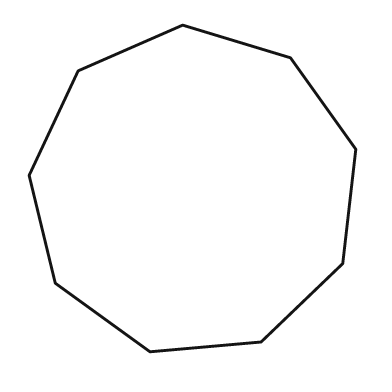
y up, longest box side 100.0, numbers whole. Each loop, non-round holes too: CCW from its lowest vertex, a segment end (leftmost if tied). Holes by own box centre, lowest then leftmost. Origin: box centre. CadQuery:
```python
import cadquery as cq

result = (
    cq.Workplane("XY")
    .moveTo(-13.0, -50.0)
    .lineTo(21.0, -47.0)
    .lineTo(46.0, -23.0)
    .lineTo(50.0, 12.0)
    .lineTo(30.0, 40.0)
    .lineTo(-3.0, 50.0)
    .lineTo(-35.0, 36.0)
    .lineTo(-50.0, 4.0)
    .lineTo(-42.0, -29.0)
    .close()
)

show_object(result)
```